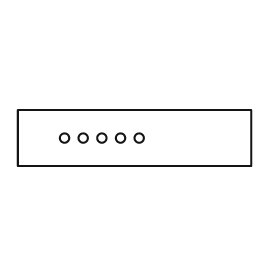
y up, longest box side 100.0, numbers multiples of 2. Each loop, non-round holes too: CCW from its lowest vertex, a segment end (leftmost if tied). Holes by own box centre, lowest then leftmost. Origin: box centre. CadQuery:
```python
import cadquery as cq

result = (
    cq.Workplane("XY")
    .moveTo(-50.0, -12.0)
    .lineTo(50.0, -12.0)
    .lineTo(50.0, 12.0)
    .lineTo(-50.0, 12.0)
    .close()
    .moveTo(-30.0, 0.0)
    .circle(2.0)
    .moveTo(-22.0, 0.0)
    .circle(2.0)
    .moveTo(-14.0, 0.0)
    .circle(2.0)
    .moveTo(-6.0, 0.0)
    .circle(2.0)
    .moveTo(2.0, 0.0)
    .circle(2.0)
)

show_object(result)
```